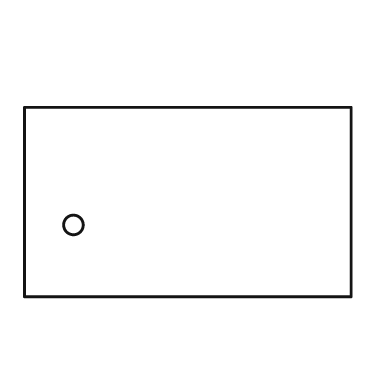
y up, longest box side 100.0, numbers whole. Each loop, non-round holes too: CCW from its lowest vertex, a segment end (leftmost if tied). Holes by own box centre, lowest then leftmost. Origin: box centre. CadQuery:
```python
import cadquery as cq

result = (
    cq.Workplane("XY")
    .moveTo(-50.0, -29.0)
    .lineTo(50.0, -29.0)
    .lineTo(50.0, 29.0)
    .lineTo(-50.0, 29.0)
    .close()
    .moveTo(-35.0, -7.0)
    .circle(3.0)
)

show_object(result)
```